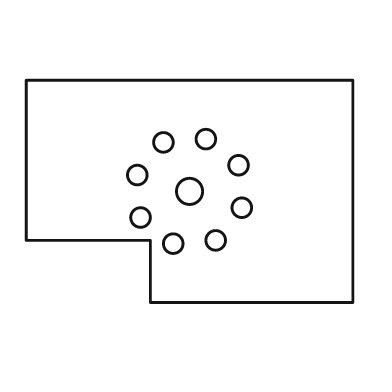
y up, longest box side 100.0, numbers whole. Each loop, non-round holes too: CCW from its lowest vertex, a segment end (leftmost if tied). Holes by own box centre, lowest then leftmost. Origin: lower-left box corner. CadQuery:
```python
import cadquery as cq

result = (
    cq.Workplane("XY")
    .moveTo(38.0, 0.0)
    .lineTo(100.0, 0.0)
    .lineTo(100.0, 68.0)
    .lineTo(0.0, 68.0)
    .lineTo(0.0, 19.0)
    .lineTo(38.0, 19.0)
    .close()
    .moveTo(45.0, 18.0)
    .circle(3.0)
    .moveTo(58.0, 19.0)
    .circle(3.0)
    .moveTo(35.0, 26.0)
    .circle(3.0)
    .moveTo(66.0, 29.0)
    .circle(3.0)
    .moveTo(50.0, 34.0)
    .circle(4.0)
    .moveTo(34.0, 39.0)
    .circle(3.0)
    .moveTo(65.0, 42.0)
    .circle(3.0)
    .moveTo(42.0, 49.0)
    .circle(3.0)
    .moveTo(55.0, 50.0)
    .circle(3.0)
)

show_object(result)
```